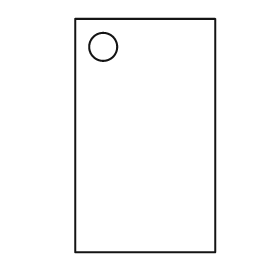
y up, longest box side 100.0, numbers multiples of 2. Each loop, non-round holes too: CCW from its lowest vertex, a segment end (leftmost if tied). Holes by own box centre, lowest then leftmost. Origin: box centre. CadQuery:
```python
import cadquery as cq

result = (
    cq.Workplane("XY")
    .moveTo(-30.0, -50.0)
    .lineTo(30.0, -50.0)
    .lineTo(30.0, 50.0)
    .lineTo(-30.0, 50.0)
    .close()
    .moveTo(-18.0, 38.0)
    .circle(6.0)
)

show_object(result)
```